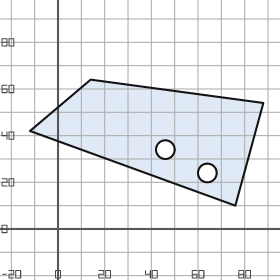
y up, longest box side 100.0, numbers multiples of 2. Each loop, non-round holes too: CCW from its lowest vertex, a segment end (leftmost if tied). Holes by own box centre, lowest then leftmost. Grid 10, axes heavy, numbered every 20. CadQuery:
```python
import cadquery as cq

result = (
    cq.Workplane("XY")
    .moveTo(76.0, 10.0)
    .lineTo(88.0, 54.0)
    .lineTo(14.0, 64.0)
    .lineTo(-12.0, 42.0)
    .close()
    .moveTo(64.0, 24.0)
    .circle(4.0)
    .moveTo(46.0, 34.0)
    .circle(4.0)
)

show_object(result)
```